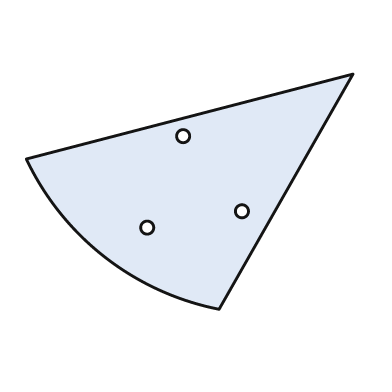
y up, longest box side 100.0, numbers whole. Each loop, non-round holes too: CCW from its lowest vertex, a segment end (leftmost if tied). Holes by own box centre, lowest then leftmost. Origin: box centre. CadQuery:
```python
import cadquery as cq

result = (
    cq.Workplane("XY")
    .moveTo(9.0, -36.0)
    .lineTo(50.0, 36.0)
    .lineTo(-50.0, 10.0)
    .threePointArc((-26.0, -20.0), (9.0, -36.0))
    .close()
    .moveTo(-13.0, -11.0)
    .circle(2.0)
    .moveTo(16.0, -6.0)
    .circle(2.0)
    .moveTo(-2.0, 17.0)
    .circle(2.0)
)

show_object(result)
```